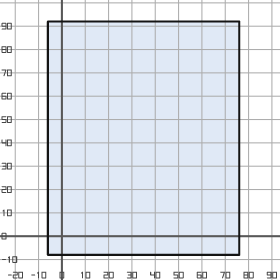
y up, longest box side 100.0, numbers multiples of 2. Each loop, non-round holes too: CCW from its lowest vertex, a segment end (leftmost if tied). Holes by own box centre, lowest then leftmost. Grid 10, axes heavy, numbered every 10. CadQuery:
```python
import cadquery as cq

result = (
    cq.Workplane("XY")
    .moveTo(-6.0, -8.0)
    .lineTo(76.0, -8.0)
    .lineTo(76.0, 92.0)
    .lineTo(-6.0, 92.0)
    .close()
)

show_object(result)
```